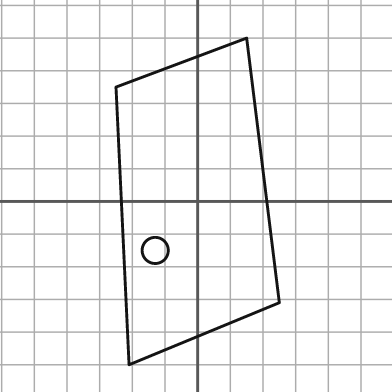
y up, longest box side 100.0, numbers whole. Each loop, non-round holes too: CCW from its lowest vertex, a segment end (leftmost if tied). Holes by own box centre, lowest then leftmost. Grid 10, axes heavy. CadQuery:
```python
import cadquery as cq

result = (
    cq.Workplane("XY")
    .moveTo(-21.0, -50.0)
    .lineTo(25.0, -31.0)
    .lineTo(15.0, 50.0)
    .lineTo(-25.0, 35.0)
    .close()
    .moveTo(-13.0, -15.0)
    .circle(4.0)
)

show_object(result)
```